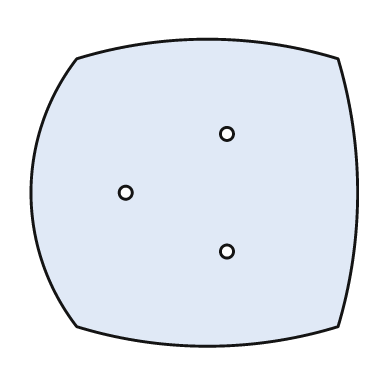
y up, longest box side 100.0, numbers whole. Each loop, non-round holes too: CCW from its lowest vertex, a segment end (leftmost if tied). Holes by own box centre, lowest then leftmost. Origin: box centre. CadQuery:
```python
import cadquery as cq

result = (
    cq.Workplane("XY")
    .moveTo(-36.0, -41.0)
    .threePointArc((4.0, -47.0), (44.0, -41.0))
    .threePointArc((50.0, 0.0), (44.0, 41.0))
    .threePointArc((4.0, 47.0), (-36.0, 41.0))
    .threePointArc((-50.0, 0.0), (-36.0, -41.0))
    .close()
    .moveTo(10.0, -18.0)
    .circle(2.0)
    .moveTo(-21.0, 0.0)
    .circle(2.0)
    .moveTo(10.0, 18.0)
    .circle(2.0)
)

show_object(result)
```